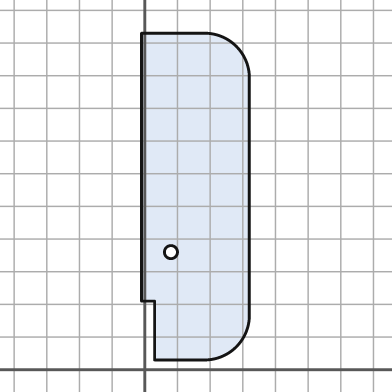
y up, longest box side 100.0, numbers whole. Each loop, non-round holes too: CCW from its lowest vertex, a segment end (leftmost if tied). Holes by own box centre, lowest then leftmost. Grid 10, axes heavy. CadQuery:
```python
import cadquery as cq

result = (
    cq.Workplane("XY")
    .moveTo(3.0, 3.0)
    .lineTo(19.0, 3.0)
    .threePointArc((28.0, 7.0), (32.0, 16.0))
    .lineTo(32.0, 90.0)
    .threePointArc((28.0, 99.0), (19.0, 103.0))
    .lineTo(-1.0, 103.0)
    .lineTo(-1.0, 21.0)
    .lineTo(3.0, 21.0)
    .close()
    .moveTo(8.0, 36.0)
    .circle(2.0)
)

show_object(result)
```